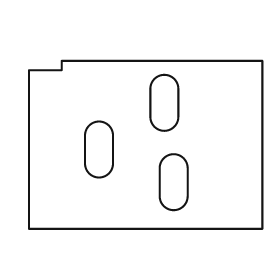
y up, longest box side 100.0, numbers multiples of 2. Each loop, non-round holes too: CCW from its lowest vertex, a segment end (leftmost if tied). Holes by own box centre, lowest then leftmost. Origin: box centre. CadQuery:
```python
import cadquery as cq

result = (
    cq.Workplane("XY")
    .moveTo(-50.0, -36.0)
    .lineTo(50.0, -36.0)
    .lineTo(50.0, 36.0)
    .lineTo(-36.0, 36.0)
    .lineTo(-36.0, 32.0)
    .lineTo(-50.0, 32.0)
    .close()
    .moveTo(6.0, -22.0)
    .threePointArc((12.0, -28.0), (18.0, -22.0))
    .lineTo(18.0, -10.0)
    .threePointArc((12.0, -4.0), (6.0, -10.0))
    .close()
    .moveTo(-26.0, -8.0)
    .threePointArc((-20.0, -14.0), (-14.0, -8.0))
    .lineTo(-14.0, 4.0)
    .threePointArc((-20.0, 10.0), (-26.0, 4.0))
    .close()
    .moveTo(2.0, 12.0)
    .threePointArc((8.0, 6.0), (14.0, 12.0))
    .lineTo(14.0, 24.0)
    .threePointArc((8.0, 30.0), (2.0, 24.0))
    .close()
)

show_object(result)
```